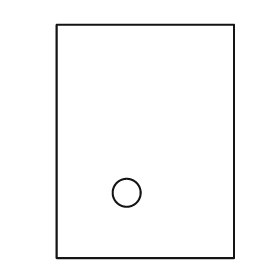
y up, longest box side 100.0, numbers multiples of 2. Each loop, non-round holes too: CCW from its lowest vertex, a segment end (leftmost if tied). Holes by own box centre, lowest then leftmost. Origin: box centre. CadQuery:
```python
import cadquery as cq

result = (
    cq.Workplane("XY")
    .moveTo(-38.0, -50.0)
    .lineTo(38.0, -50.0)
    .lineTo(38.0, 50.0)
    .lineTo(-38.0, 50.0)
    .close()
    .moveTo(-8.0, -22.0)
    .circle(6.0)
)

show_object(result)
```